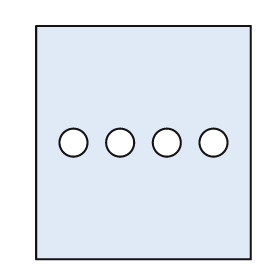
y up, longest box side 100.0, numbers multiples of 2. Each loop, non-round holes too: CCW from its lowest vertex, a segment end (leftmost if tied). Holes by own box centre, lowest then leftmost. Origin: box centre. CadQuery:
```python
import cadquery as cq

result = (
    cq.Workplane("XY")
    .moveTo(-46.0, -50.0)
    .lineTo(46.0, -50.0)
    .lineTo(46.0, 50.0)
    .lineTo(-46.0, 50.0)
    .close()
    .moveTo(-30.0, 0.0)
    .circle(6.0)
    .moveTo(-10.0, 0.0)
    .circle(6.0)
    .moveTo(10.0, 0.0)
    .circle(6.0)
    .moveTo(30.0, 0.0)
    .circle(6.0)
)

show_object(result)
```